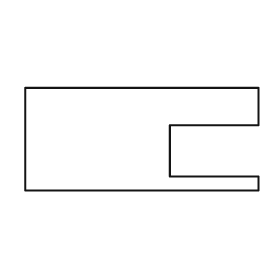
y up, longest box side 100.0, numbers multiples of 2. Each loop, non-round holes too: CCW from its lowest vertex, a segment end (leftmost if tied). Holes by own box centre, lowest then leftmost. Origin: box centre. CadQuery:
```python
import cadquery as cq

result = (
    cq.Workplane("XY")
    .moveTo(-50.0, -22.0)
    .lineTo(50.0, -22.0)
    .lineTo(50.0, -16.0)
    .lineTo(12.0, -16.0)
    .lineTo(12.0, 6.0)
    .lineTo(50.0, 6.0)
    .lineTo(50.0, 22.0)
    .lineTo(-50.0, 22.0)
    .close()
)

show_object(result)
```